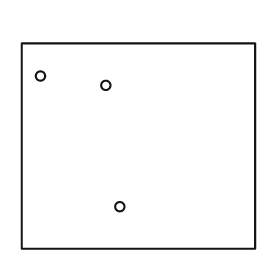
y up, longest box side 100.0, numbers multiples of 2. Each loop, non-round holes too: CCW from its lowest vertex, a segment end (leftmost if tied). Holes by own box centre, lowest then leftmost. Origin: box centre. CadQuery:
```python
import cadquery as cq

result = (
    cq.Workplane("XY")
    .moveTo(-50.0, -44.0)
    .lineTo(50.0, -44.0)
    .lineTo(50.0, 44.0)
    .lineTo(-50.0, 44.0)
    .close()
    .moveTo(-8.0, -26.0)
    .circle(2.0)
    .moveTo(-14.0, 26.0)
    .circle(2.0)
    .moveTo(-42.0, 30.0)
    .circle(2.0)
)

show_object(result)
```